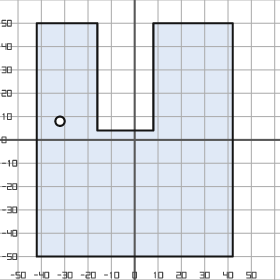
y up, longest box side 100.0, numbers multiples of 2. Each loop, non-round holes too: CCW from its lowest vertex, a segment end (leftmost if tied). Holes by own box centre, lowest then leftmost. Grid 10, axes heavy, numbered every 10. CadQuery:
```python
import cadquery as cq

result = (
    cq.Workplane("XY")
    .moveTo(-42.0, -50.0)
    .lineTo(42.0, -50.0)
    .lineTo(42.0, 50.0)
    .lineTo(8.0, 50.0)
    .lineTo(8.0, 4.0)
    .lineTo(-16.0, 4.0)
    .lineTo(-16.0, 50.0)
    .lineTo(-42.0, 50.0)
    .close()
    .moveTo(-32.0, 8.0)
    .circle(2.0)
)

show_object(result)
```